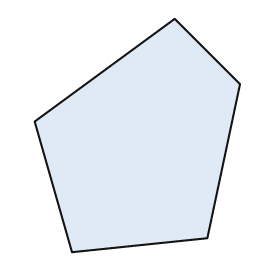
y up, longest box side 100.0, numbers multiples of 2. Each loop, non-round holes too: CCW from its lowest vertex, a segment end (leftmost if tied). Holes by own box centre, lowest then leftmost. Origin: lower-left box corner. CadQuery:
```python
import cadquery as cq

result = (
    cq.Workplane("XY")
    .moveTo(16.0, 0.0)
    .lineTo(74.0, 6.0)
    .lineTo(88.0, 72.0)
    .lineTo(60.0, 100.0)
    .lineTo(0.0, 56.0)
    .close()
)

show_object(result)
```